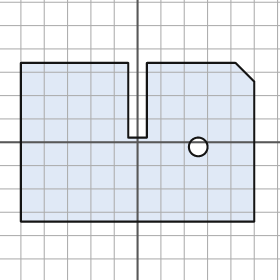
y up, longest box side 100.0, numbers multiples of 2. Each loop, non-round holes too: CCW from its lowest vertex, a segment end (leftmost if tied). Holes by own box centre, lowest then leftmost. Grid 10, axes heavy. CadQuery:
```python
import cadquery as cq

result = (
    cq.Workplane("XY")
    .moveTo(-50.0, -34.0)
    .lineTo(50.0, -34.0)
    .lineTo(50.0, 26.0)
    .lineTo(42.0, 34.0)
    .lineTo(4.0, 34.0)
    .lineTo(4.0, 2.0)
    .lineTo(-4.0, 2.0)
    .lineTo(-4.0, 34.0)
    .lineTo(-50.0, 34.0)
    .close()
    .moveTo(26.0, -2.0)
    .circle(4.0)
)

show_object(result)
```